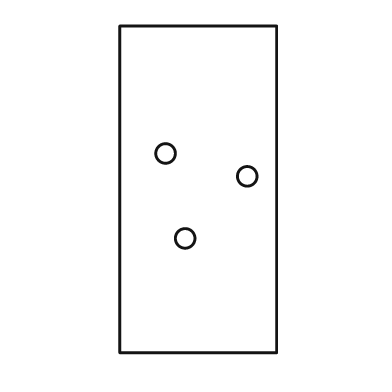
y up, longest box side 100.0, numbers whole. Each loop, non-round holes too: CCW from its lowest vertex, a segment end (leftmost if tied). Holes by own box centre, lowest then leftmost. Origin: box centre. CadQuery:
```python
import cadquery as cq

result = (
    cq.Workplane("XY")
    .moveTo(-24.0, -50.0)
    .lineTo(24.0, -50.0)
    .lineTo(24.0, 50.0)
    .lineTo(-24.0, 50.0)
    .close()
    .moveTo(-4.0, -15.0)
    .circle(3.0)
    .moveTo(15.0, 4.0)
    .circle(3.0)
    .moveTo(-10.0, 11.0)
    .circle(3.0)
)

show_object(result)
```